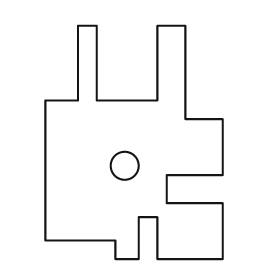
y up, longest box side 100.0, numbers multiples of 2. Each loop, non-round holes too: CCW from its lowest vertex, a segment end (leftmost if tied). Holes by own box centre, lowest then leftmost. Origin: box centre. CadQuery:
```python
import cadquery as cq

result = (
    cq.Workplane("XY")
    .moveTo(-8.0, -50.0)
    .lineTo(2.0, -50.0)
    .lineTo(2.0, -32.0)
    .lineTo(10.0, -32.0)
    .lineTo(10.0, -50.0)
    .lineTo(38.0, -50.0)
    .lineTo(38.0, -26.0)
    .lineTo(14.0, -26.0)
    .lineTo(14.0, -14.0)
    .lineTo(38.0, -14.0)
    .lineTo(38.0, 10.0)
    .lineTo(22.0, 10.0)
    .lineTo(22.0, 50.0)
    .lineTo(10.0, 50.0)
    .lineTo(10.0, 18.0)
    .lineTo(-16.0, 18.0)
    .lineTo(-16.0, 50.0)
    .lineTo(-24.0, 50.0)
    .lineTo(-24.0, 18.0)
    .lineTo(-38.0, 18.0)
    .lineTo(-38.0, -42.0)
    .lineTo(-8.0, -42.0)
    .close()
    .moveTo(-4.0, -10.0)
    .circle(6.0)
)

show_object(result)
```